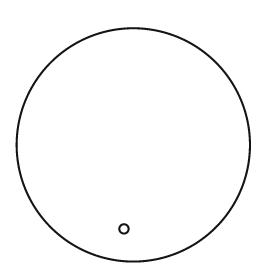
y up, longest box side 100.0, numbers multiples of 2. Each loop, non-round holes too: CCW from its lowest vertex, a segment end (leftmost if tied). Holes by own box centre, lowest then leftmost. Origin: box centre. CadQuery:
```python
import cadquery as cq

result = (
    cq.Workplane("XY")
    .moveTo(0.0, 0.0)
    .circle(50.0)
    .moveTo(-4.0, -36.0)
    .circle(2.0)
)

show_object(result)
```